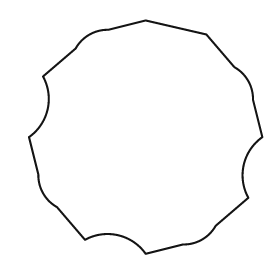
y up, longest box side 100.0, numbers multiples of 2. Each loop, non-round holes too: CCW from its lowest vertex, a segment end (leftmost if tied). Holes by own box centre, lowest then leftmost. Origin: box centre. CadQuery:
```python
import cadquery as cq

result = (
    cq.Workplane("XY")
    .moveTo(0.0, -50.0)
    .lineTo(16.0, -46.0)
    .threePointArc((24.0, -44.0), (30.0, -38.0))
    .lineTo(44.0, -26.0)
    .threePointArc((42.0, -12.0), (50.0, 0.0))
    .lineTo(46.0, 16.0)
    .threePointArc((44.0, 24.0), (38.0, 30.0))
    .lineTo(26.0, 44.0)
    .lineTo(0.0, 50.0)
    .lineTo(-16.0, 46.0)
    .threePointArc((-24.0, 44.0), (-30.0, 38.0))
    .lineTo(-44.0, 26.0)
    .threePointArc((-42.0, 12.0), (-50.0, 0.0))
    .lineTo(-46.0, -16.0)
    .threePointArc((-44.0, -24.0), (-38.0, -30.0))
    .lineTo(-26.0, -44.0)
    .threePointArc((-12.0, -42.0), (0.0, -50.0))
    .close()
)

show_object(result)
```